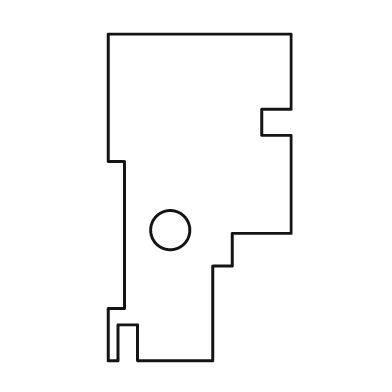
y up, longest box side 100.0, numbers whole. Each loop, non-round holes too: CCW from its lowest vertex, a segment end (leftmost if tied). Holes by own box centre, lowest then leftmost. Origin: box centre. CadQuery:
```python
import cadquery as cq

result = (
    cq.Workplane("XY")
    .moveTo(-28.0, -50.0)
    .lineTo(-25.0, -50.0)
    .lineTo(-25.0, -39.0)
    .lineTo(-19.0, -39.0)
    .lineTo(-19.0, -50.0)
    .lineTo(4.0, -50.0)
    .lineTo(4.0, -21.0)
    .lineTo(10.0, -21.0)
    .lineTo(10.0, -11.0)
    .lineTo(28.0, -11.0)
    .lineTo(28.0, 19.0)
    .lineTo(19.0, 19.0)
    .lineTo(19.0, 27.0)
    .lineTo(28.0, 27.0)
    .lineTo(28.0, 50.0)
    .lineTo(-28.0, 50.0)
    .lineTo(-28.0, 11.0)
    .lineTo(-23.0, 11.0)
    .lineTo(-23.0, -34.0)
    .lineTo(-28.0, -34.0)
    .close()
    .moveTo(-9.0, -10.0)
    .circle(6.0)
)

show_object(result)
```